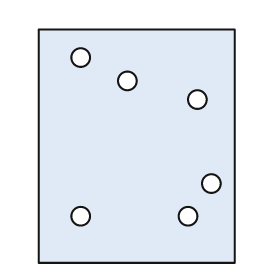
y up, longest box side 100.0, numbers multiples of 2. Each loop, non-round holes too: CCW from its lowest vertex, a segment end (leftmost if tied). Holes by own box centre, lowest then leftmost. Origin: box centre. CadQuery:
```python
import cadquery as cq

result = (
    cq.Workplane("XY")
    .moveTo(-42.0, -50.0)
    .lineTo(42.0, -50.0)
    .lineTo(42.0, 50.0)
    .lineTo(-42.0, 50.0)
    .close()
    .moveTo(-24.0, -30.0)
    .circle(4.0)
    .moveTo(22.0, -30.0)
    .circle(4.0)
    .moveTo(32.0, -16.0)
    .circle(4.0)
    .moveTo(26.0, 20.0)
    .circle(4.0)
    .moveTo(-4.0, 28.0)
    .circle(4.0)
    .moveTo(-24.0, 38.0)
    .circle(4.0)
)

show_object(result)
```